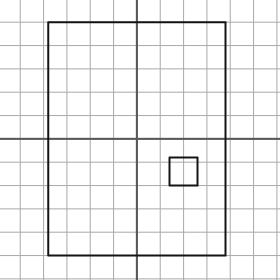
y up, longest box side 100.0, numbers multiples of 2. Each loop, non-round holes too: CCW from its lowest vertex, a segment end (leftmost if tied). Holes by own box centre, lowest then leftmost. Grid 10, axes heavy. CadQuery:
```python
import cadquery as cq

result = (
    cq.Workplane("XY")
    .moveTo(-38.0, -50.0)
    .lineTo(38.0, -50.0)
    .lineTo(38.0, 50.0)
    .lineTo(-38.0, 50.0)
    .close()
    .moveTo(14.0, -20.0)
    .lineTo(26.0, -20.0)
    .lineTo(26.0, -8.0)
    .lineTo(14.0, -8.0)
    .close()
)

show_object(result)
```